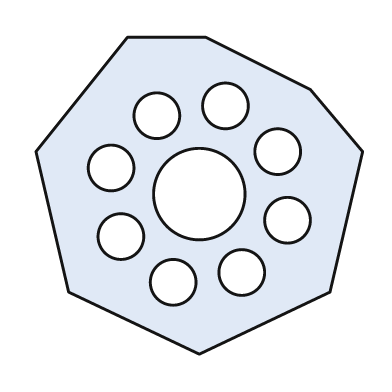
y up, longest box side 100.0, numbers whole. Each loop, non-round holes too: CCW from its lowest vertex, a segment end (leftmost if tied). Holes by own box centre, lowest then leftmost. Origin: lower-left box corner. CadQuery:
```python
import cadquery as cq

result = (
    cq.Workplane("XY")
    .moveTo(50.0, 0.0)
    .lineTo(90.0, 19.0)
    .lineTo(100.0, 62.0)
    .lineTo(84.0, 81.0)
    .lineTo(52.0, 97.0)
    .lineTo(28.0, 97.0)
    .lineTo(0.0, 62.0)
    .lineTo(10.0, 19.0)
    .close()
    .moveTo(42.0, 22.0)
    .circle(7.0)
    .moveTo(63.0, 25.0)
    .circle(7.0)
    .moveTo(26.0, 36.0)
    .circle(7.0)
    .moveTo(77.0, 41.0)
    .circle(7.0)
    .moveTo(50.0, 49.0)
    .circle(14.0)
    .moveTo(23.0, 57.0)
    .circle(7.0)
    .moveTo(74.0, 62.0)
    .circle(7.0)
    .moveTo(37.0, 73.0)
    .circle(7.0)
    .moveTo(58.0, 76.0)
    .circle(7.0)
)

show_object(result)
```